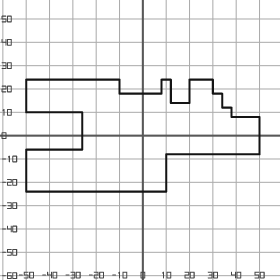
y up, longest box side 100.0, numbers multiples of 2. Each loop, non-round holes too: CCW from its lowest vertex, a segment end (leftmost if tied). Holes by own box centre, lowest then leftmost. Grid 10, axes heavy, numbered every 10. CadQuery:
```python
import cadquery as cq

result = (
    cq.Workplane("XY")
    .moveTo(-50.0, -24.0)
    .lineTo(10.0, -24.0)
    .lineTo(10.0, -8.0)
    .lineTo(50.0, -8.0)
    .lineTo(50.0, 8.0)
    .lineTo(38.0, 8.0)
    .lineTo(38.0, 12.0)
    .lineTo(34.0, 12.0)
    .lineTo(34.0, 18.0)
    .lineTo(30.0, 18.0)
    .lineTo(30.0, 24.0)
    .lineTo(20.0, 24.0)
    .lineTo(20.0, 14.0)
    .lineTo(12.0, 14.0)
    .lineTo(12.0, 24.0)
    .lineTo(8.0, 24.0)
    .lineTo(8.0, 18.0)
    .lineTo(-10.0, 18.0)
    .lineTo(-10.0, 24.0)
    .lineTo(-50.0, 24.0)
    .lineTo(-50.0, 10.0)
    .lineTo(-26.0, 10.0)
    .lineTo(-26.0, -6.0)
    .lineTo(-50.0, -6.0)
    .close()
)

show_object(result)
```